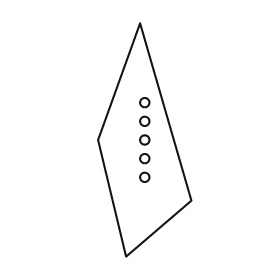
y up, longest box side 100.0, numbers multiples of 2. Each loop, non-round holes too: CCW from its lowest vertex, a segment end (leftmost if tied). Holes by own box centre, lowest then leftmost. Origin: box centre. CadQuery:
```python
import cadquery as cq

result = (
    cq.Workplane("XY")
    .moveTo(-8.0, -50.0)
    .lineTo(20.0, -26.0)
    .lineTo(-2.0, 50.0)
    .lineTo(-20.0, 0.0)
    .close()
    .moveTo(0.0, -16.0)
    .circle(2.0)
    .moveTo(0.0, -8.0)
    .circle(2.0)
    .moveTo(0.0, 0.0)
    .circle(2.0)
    .moveTo(0.0, 8.0)
    .circle(2.0)
    .moveTo(0.0, 16.0)
    .circle(2.0)
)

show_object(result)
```